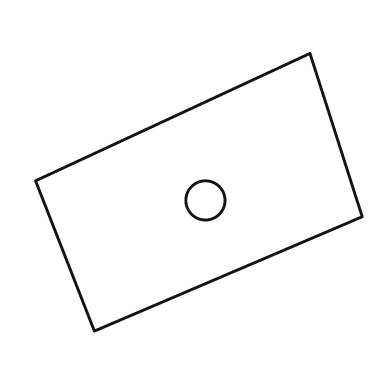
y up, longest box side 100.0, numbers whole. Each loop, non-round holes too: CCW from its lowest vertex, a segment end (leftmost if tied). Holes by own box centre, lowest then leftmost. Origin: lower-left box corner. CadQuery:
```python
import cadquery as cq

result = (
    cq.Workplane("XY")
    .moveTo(18.0, 0.0)
    .lineTo(100.0, 35.0)
    .lineTo(84.0, 85.0)
    .lineTo(0.0, 46.0)
    .close()
    .moveTo(52.0, 40.0)
    .circle(6.0)
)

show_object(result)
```